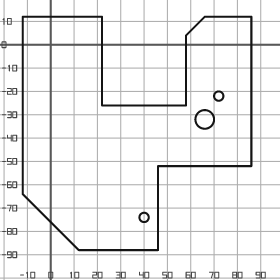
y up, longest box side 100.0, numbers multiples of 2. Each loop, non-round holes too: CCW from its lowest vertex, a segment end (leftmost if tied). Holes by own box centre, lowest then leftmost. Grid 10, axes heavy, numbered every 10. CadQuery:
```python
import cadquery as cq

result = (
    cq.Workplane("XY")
    .moveTo(12.0, -88.0)
    .lineTo(46.0, -88.0)
    .lineTo(46.0, -52.0)
    .lineTo(86.0, -52.0)
    .lineTo(86.0, 12.0)
    .lineTo(66.0, 12.0)
    .lineTo(58.0, 4.0)
    .lineTo(58.0, -26.0)
    .lineTo(22.0, -26.0)
    .lineTo(22.0, 12.0)
    .lineTo(-12.0, 12.0)
    .lineTo(-12.0, -64.0)
    .close()
    .moveTo(40.0, -74.0)
    .circle(2.0)
    .moveTo(66.0, -32.0)
    .circle(4.0)
    .moveTo(72.0, -22.0)
    .circle(2.0)
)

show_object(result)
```